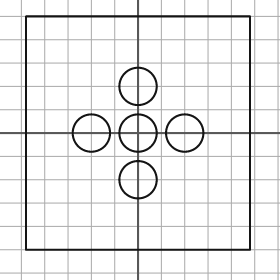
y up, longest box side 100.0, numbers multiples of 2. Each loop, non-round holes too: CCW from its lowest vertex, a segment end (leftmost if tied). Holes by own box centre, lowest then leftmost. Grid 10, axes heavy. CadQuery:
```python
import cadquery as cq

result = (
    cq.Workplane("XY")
    .moveTo(-48.0, -50.0)
    .lineTo(48.0, -50.0)
    .lineTo(48.0, 50.0)
    .lineTo(-48.0, 50.0)
    .close()
    .moveTo(0.0, -20.0)
    .circle(8.0)
    .moveTo(-20.0, 0.0)
    .circle(8.0)
    .moveTo(0.0, 0.0)
    .circle(8.0)
    .moveTo(20.0, 0.0)
    .circle(8.0)
    .moveTo(0.0, 20.0)
    .circle(8.0)
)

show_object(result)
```